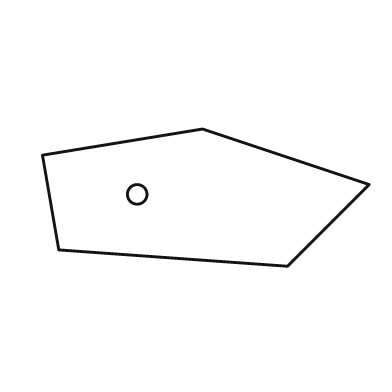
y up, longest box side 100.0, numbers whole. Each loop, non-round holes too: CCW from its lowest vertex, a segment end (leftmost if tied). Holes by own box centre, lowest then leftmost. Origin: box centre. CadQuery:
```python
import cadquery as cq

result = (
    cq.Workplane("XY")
    .moveTo(25.0, -21.0)
    .lineTo(50.0, 4.0)
    .lineTo(-1.0, 21.0)
    .lineTo(-50.0, 13.0)
    .lineTo(-45.0, -16.0)
    .close()
    .moveTo(-21.0, 1.0)
    .circle(3.0)
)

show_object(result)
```